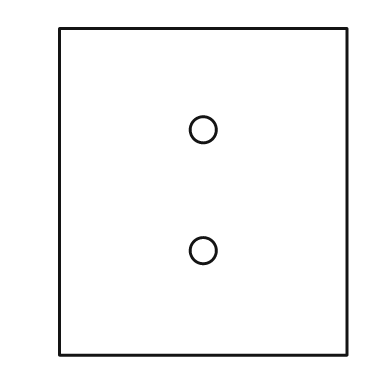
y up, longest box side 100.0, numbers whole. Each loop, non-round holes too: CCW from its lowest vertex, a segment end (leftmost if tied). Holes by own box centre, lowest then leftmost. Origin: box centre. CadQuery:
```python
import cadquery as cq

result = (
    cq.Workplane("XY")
    .moveTo(-44.0, -50.0)
    .lineTo(44.0, -50.0)
    .lineTo(44.0, 50.0)
    .lineTo(-44.0, 50.0)
    .close()
    .moveTo(0.0, -18.0)
    .circle(4.0)
    .moveTo(0.0, 19.0)
    .circle(4.0)
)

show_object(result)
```